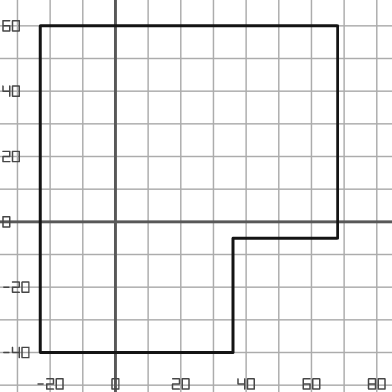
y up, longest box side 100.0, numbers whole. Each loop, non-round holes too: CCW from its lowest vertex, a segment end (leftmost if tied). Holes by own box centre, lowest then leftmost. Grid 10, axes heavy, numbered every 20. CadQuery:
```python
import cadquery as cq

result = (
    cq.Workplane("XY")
    .moveTo(-23.0, -40.0)
    .lineTo(36.0, -40.0)
    .lineTo(36.0, -5.0)
    .lineTo(68.0, -5.0)
    .lineTo(68.0, 60.0)
    .lineTo(-23.0, 60.0)
    .close()
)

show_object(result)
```